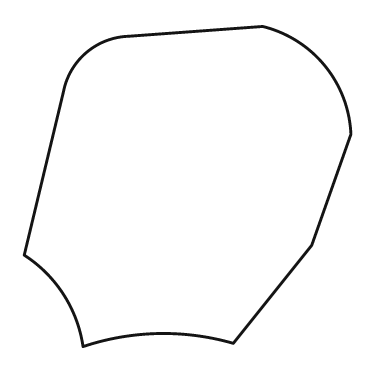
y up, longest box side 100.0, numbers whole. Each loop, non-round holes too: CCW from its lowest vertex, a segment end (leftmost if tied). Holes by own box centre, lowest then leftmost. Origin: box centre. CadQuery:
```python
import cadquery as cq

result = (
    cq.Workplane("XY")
    .moveTo(-32.0, -49.0)
    .threePointArc((-9.0, -45.0), (14.0, -48.0))
    .lineTo(38.0, -18.0)
    .lineTo(50.0, 16.0)
    .threePointArc((42.0, 37.0), (23.0, 49.0))
    .lineTo(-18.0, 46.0)
    .threePointArc((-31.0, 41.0), (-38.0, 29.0))
    .lineTo(-50.0, -21.0)
    .threePointArc((-38.0, -33.0), (-32.0, -49.0))
    .close()
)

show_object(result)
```